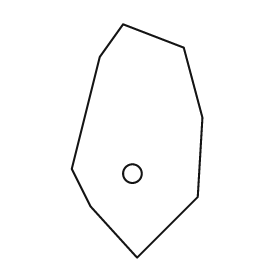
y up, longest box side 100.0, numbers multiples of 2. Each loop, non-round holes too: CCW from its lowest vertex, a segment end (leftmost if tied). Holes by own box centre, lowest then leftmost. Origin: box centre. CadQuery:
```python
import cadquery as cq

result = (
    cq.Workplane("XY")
    .moveTo(0.0, -50.0)
    .lineTo(26.0, -24.0)
    .lineTo(28.0, 10.0)
    .lineTo(20.0, 40.0)
    .lineTo(-6.0, 50.0)
    .lineTo(-16.0, 36.0)
    .lineTo(-28.0, -12.0)
    .lineTo(-20.0, -28.0)
    .close()
    .moveTo(-2.0, -14.0)
    .circle(4.0)
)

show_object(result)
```